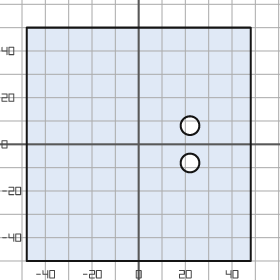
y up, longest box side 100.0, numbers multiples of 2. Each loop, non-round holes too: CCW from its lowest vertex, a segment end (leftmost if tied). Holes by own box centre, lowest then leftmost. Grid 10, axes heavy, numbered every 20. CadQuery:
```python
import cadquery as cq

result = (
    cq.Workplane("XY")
    .moveTo(-48.0, -50.0)
    .lineTo(48.0, -50.0)
    .lineTo(48.0, 50.0)
    .lineTo(-48.0, 50.0)
    .close()
    .moveTo(22.0, -8.0)
    .circle(4.0)
    .moveTo(22.0, 8.0)
    .circle(4.0)
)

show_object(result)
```